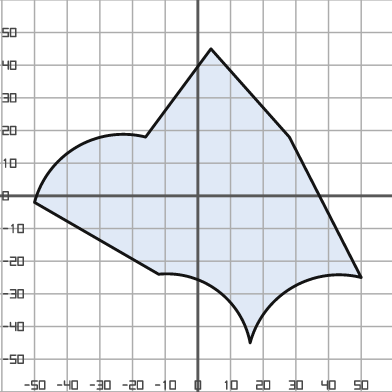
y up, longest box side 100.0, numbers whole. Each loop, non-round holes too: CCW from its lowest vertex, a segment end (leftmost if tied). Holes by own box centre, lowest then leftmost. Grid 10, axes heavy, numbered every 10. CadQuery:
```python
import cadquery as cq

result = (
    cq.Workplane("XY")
    .moveTo(16.0, -45.0)
    .threePointArc((29.0, -28.0), (50.0, -25.0))
    .lineTo(28.0, 18.0)
    .lineTo(4.0, 45.0)
    .lineTo(-16.0, 18.0)
    .threePointArc((-37.0, 15.0), (-50.0, -2.0))
    .lineTo(-12.0, -24.0)
    .threePointArc((6.0, -29.0), (16.0, -45.0))
    .close()
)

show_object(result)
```